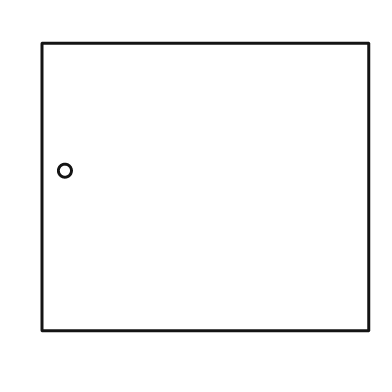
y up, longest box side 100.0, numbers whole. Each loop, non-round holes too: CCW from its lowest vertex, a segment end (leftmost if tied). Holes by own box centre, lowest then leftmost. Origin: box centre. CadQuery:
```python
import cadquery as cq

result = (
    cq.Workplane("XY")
    .moveTo(-50.0, -44.0)
    .lineTo(50.0, -44.0)
    .lineTo(50.0, 44.0)
    .lineTo(-50.0, 44.0)
    .close()
    .moveTo(-43.0, 5.0)
    .circle(2.0)
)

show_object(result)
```